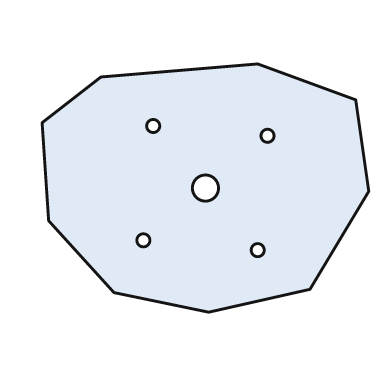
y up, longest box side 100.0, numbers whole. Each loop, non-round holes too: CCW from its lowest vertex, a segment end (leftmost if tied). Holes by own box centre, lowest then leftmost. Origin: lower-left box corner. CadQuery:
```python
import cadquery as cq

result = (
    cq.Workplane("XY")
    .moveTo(51.0, 0.0)
    .lineTo(82.0, 7.0)
    .lineTo(100.0, 37.0)
    .lineTo(96.0, 65.0)
    .lineTo(66.0, 76.0)
    .lineTo(18.0, 72.0)
    .lineTo(0.0, 58.0)
    .lineTo(2.0, 28.0)
    .lineTo(22.0, 6.0)
    .close()
    .moveTo(66.0, 19.0)
    .circle(2.0)
    .moveTo(31.0, 22.0)
    .circle(2.0)
    .moveTo(50.0, 38.0)
    .circle(4.0)
    .moveTo(69.0, 54.0)
    .circle(2.0)
    .moveTo(34.0, 57.0)
    .circle(2.0)
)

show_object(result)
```